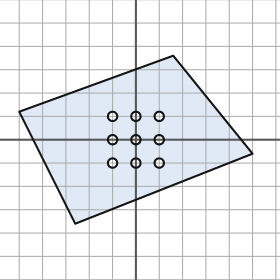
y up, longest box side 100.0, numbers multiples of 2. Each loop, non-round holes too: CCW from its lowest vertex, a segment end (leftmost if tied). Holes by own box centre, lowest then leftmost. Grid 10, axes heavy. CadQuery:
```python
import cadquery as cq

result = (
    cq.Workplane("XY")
    .moveTo(-26.0, -36.0)
    .lineTo(50.0, -6.0)
    .lineTo(16.0, 36.0)
    .lineTo(-50.0, 12.0)
    .close()
    .moveTo(-10.0, -10.0)
    .circle(2.0)
    .moveTo(0.0, -10.0)
    .circle(2.0)
    .moveTo(10.0, -10.0)
    .circle(2.0)
    .moveTo(-10.0, 0.0)
    .circle(2.0)
    .moveTo(0.0, 0.0)
    .circle(2.0)
    .moveTo(10.0, 0.0)
    .circle(2.0)
    .moveTo(-10.0, 10.0)
    .circle(2.0)
    .moveTo(0.0, 10.0)
    .circle(2.0)
    .moveTo(10.0, 10.0)
    .circle(2.0)
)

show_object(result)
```